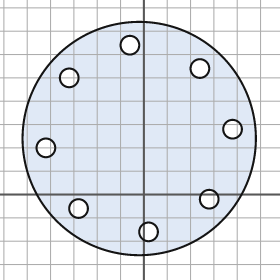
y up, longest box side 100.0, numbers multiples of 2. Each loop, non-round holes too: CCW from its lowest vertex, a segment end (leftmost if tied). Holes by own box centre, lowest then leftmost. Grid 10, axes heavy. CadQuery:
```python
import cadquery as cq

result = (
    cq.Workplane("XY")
    .moveTo(-2.0, 24.0)
    .circle(50.0)
    .moveTo(2.0, -16.0)
    .circle(4.0)
    .moveTo(-28.0, -6.0)
    .circle(4.0)
    .moveTo(28.0, -2.0)
    .circle(4.0)
    .moveTo(-42.0, 20.0)
    .circle(4.0)
    .moveTo(38.0, 28.0)
    .circle(4.0)
    .moveTo(-32.0, 50.0)
    .circle(4.0)
    .moveTo(24.0, 54.0)
    .circle(4.0)
    .moveTo(-6.0, 64.0)
    .circle(4.0)
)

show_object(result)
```